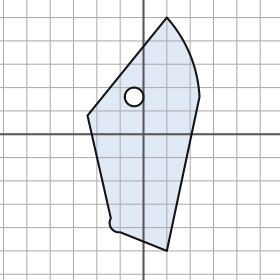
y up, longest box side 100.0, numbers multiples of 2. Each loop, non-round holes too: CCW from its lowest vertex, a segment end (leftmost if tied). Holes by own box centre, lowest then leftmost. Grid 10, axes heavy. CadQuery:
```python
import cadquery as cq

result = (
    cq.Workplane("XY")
    .moveTo(10.0, -50.0)
    .lineTo(24.0, 16.0)
    .threePointArc((20.0, 34.0), (10.0, 50.0))
    .lineTo(-24.0, 8.0)
    .lineTo(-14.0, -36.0)
    .threePointArc((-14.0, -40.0), (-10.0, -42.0))
    .close()
    .moveTo(-4.0, 16.0)
    .circle(4.0)
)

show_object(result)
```